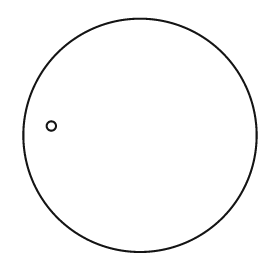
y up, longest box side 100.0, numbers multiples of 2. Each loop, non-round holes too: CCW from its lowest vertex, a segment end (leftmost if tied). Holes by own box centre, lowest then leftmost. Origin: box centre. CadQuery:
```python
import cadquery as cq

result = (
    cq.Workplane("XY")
    .moveTo(0.0, 0.0)
    .circle(50.0)
    .moveTo(-38.0, 4.0)
    .circle(2.0)
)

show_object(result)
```